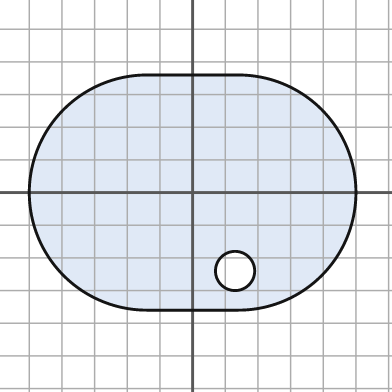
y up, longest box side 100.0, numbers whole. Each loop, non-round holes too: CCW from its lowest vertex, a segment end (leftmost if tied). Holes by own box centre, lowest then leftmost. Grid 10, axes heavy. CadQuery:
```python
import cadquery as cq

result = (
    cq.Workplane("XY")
    .moveTo(-14.0, -36.0)
    .lineTo(14.0, -36.0)
    .threePointArc((50.0, 0.0), (14.0, 36.0))
    .lineTo(-14.0, 36.0)
    .threePointArc((-50.0, 0.0), (-14.0, -36.0))
    .close()
    .moveTo(13.0, -24.0)
    .circle(6.0)
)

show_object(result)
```